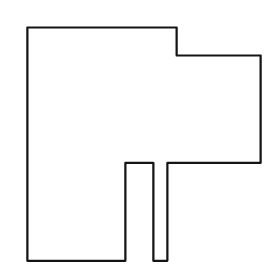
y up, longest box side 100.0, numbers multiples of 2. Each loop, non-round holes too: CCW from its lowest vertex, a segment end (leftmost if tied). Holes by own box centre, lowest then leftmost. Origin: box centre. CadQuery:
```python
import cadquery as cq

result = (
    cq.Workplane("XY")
    .moveTo(-50.0, -50.0)
    .lineTo(-8.0, -50.0)
    .lineTo(-8.0, -8.0)
    .lineTo(4.0, -8.0)
    .lineTo(4.0, -50.0)
    .lineTo(10.0, -50.0)
    .lineTo(10.0, -8.0)
    .lineTo(50.0, -8.0)
    .lineTo(50.0, 38.0)
    .lineTo(14.0, 38.0)
    .lineTo(14.0, 50.0)
    .lineTo(-50.0, 50.0)
    .close()
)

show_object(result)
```